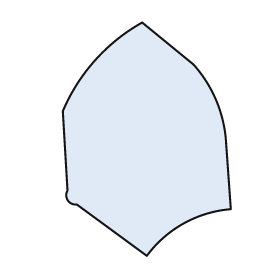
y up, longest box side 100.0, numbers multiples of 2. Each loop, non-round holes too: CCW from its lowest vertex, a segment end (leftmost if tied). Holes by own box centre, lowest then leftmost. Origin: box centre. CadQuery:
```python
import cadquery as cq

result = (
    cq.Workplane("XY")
    .moveTo(0.0, -50.0)
    .threePointArc((16.0, -36.0), (36.0, -30.0))
    .lineTo(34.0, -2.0)
    .threePointArc((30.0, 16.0), (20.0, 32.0))
    .lineTo(-2.0, 50.0)
    .threePointArc((-22.0, 34.0), (-36.0, 12.0))
    .lineTo(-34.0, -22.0)
    .threePointArc((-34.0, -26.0), (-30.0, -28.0))
    .close()
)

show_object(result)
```